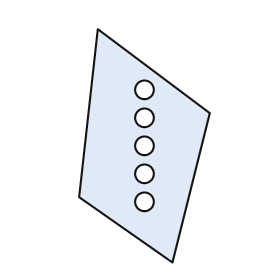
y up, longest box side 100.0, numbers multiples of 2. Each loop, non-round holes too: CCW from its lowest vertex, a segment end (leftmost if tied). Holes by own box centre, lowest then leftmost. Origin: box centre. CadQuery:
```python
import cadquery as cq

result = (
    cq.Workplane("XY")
    .moveTo(12.0, -50.0)
    .lineTo(28.0, 14.0)
    .lineTo(-20.0, 50.0)
    .lineTo(-28.0, -22.0)
    .close()
    .moveTo(0.0, -24.0)
    .circle(4.0)
    .moveTo(0.0, -12.0)
    .circle(4.0)
    .moveTo(0.0, 0.0)
    .circle(4.0)
    .moveTo(0.0, 12.0)
    .circle(4.0)
    .moveTo(0.0, 24.0)
    .circle(4.0)
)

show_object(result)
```